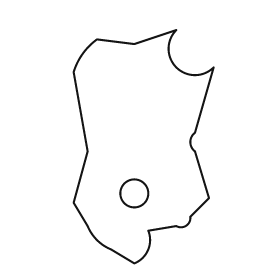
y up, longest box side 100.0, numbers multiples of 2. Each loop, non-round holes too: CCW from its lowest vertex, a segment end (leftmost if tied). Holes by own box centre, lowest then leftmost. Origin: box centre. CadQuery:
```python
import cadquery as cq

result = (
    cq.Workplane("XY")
    .moveTo(-4.0, -50.0)
    .threePointArc((2.0, -44.0), (2.0, -36.0))
    .lineTo(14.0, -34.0)
    .threePointArc((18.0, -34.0), (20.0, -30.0))
    .lineTo(28.0, -22.0)
    .lineTo(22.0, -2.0)
    .threePointArc((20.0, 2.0), (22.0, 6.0))
    .lineTo(30.0, 34.0)
    .threePointArc((14.0, 34.0), (14.0, 50.0))
    .lineTo(-4.0, 44.0)
    .lineTo(-20.0, 46.0)
    .threePointArc((-26.0, 40.0), (-30.0, 32.0))
    .lineTo(-24.0, -2.0)
    .lineTo(-30.0, -24.0)
    .lineTo(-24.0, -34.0)
    .threePointArc((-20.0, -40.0), (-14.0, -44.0))
    .close()
    .moveTo(-4.0, -20.0)
    .circle(6.0)
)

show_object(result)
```